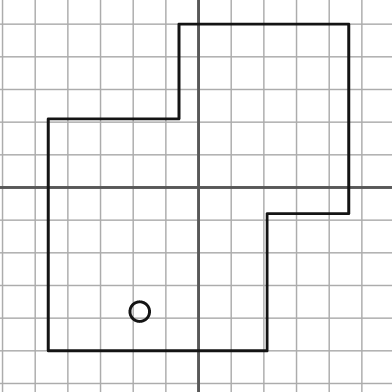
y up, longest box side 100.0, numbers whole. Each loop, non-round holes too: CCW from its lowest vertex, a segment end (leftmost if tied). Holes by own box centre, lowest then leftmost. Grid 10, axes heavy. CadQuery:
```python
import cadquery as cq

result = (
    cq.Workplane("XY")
    .moveTo(-46.0, -50.0)
    .lineTo(21.0, -50.0)
    .lineTo(21.0, -8.0)
    .lineTo(46.0, -8.0)
    .lineTo(46.0, 50.0)
    .lineTo(-6.0, 50.0)
    .lineTo(-6.0, 21.0)
    .lineTo(-46.0, 21.0)
    .close()
    .moveTo(-18.0, -38.0)
    .circle(3.0)
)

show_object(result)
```